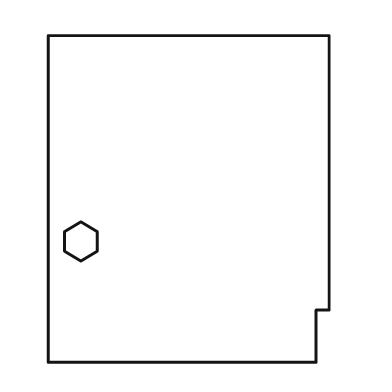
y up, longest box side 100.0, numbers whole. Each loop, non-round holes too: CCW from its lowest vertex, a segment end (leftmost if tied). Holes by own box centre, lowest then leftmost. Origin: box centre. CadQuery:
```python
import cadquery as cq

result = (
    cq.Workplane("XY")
    .moveTo(-43.0, -50.0)
    .lineTo(39.0, -50.0)
    .lineTo(39.0, -34.0)
    .lineTo(43.0, -34.0)
    .lineTo(43.0, 50.0)
    .lineTo(-43.0, 50.0)
    .close()
    .moveTo(-33.0, -19.0)
    .lineTo(-28.0, -16.0)
    .lineTo(-28.0, -10.0)
    .lineTo(-33.0, -7.0)
    .lineTo(-38.0, -10.0)
    .lineTo(-38.0, -16.0)
    .close()
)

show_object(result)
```